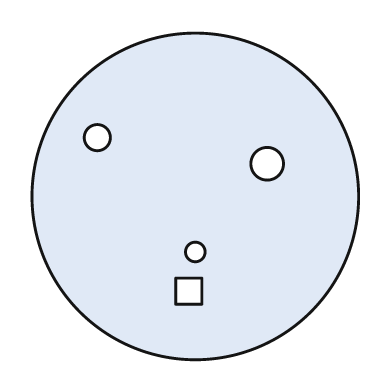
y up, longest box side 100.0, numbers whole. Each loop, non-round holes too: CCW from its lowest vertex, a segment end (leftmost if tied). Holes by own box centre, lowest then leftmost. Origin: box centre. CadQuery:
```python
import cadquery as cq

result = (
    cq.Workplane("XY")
    .moveTo(0.0, 0.0)
    .circle(50.0)
    .moveTo(-6.0, -33.0)
    .lineTo(2.0, -33.0)
    .lineTo(2.0, -25.0)
    .lineTo(-6.0, -25.0)
    .close()
    .moveTo(0.0, -17.0)
    .circle(3.0)
    .moveTo(22.0, 10.0)
    .circle(5.0)
    .moveTo(-30.0, 18.0)
    .circle(4.0)
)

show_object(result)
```